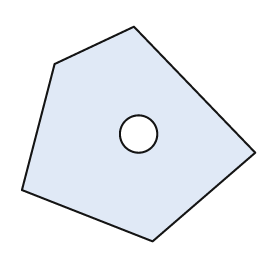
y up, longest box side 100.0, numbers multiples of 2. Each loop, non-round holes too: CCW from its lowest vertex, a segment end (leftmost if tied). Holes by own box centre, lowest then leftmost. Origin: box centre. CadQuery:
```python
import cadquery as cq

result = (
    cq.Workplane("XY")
    .moveTo(6.0, -46.0)
    .lineTo(50.0, -8.0)
    .lineTo(-2.0, 46.0)
    .lineTo(-36.0, 30.0)
    .lineTo(-50.0, -24.0)
    .close()
    .moveTo(0.0, 0.0)
    .circle(8.0)
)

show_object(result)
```